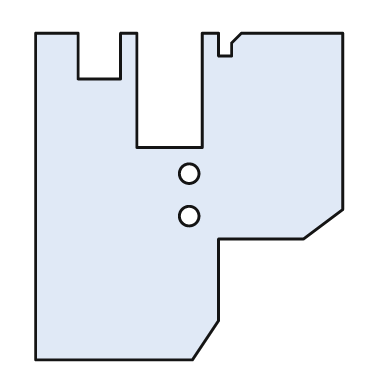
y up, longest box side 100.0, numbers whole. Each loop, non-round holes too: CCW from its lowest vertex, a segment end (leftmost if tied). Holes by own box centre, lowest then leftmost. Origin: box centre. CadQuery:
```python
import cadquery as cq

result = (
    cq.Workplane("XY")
    .moveTo(-47.0, -50.0)
    .lineTo(1.0, -50.0)
    .lineTo(9.0, -38.0)
    .lineTo(9.0, -13.0)
    .lineTo(35.0, -13.0)
    .lineTo(47.0, -4.0)
    .lineTo(47.0, 50.0)
    .lineTo(16.0, 50.0)
    .lineTo(13.0, 47.0)
    .lineTo(13.0, 43.0)
    .lineTo(9.0, 43.0)
    .lineTo(9.0, 50.0)
    .lineTo(4.0, 50.0)
    .lineTo(4.0, 15.0)
    .lineTo(-16.0, 15.0)
    .lineTo(-16.0, 50.0)
    .lineTo(-21.0, 50.0)
    .lineTo(-21.0, 36.0)
    .lineTo(-34.0, 36.0)
    .lineTo(-34.0, 50.0)
    .lineTo(-47.0, 50.0)
    .close()
    .moveTo(0.0, -6.0)
    .circle(3.0)
    .moveTo(0.0, 7.0)
    .circle(3.0)
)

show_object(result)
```